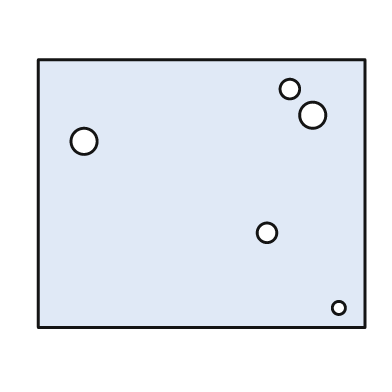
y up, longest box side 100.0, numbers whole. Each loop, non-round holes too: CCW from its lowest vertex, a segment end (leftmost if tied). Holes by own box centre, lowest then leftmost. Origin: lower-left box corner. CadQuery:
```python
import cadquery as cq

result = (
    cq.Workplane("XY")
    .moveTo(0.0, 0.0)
    .lineTo(100.0, 0.0)
    .lineTo(100.0, 82.0)
    .lineTo(0.0, 82.0)
    .close()
    .moveTo(92.0, 6.0)
    .circle(2.0)
    .moveTo(70.0, 29.0)
    .circle(3.0)
    .moveTo(14.0, 57.0)
    .circle(4.0)
    .moveTo(84.0, 65.0)
    .circle(4.0)
    .moveTo(77.0, 73.0)
    .circle(3.0)
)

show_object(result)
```